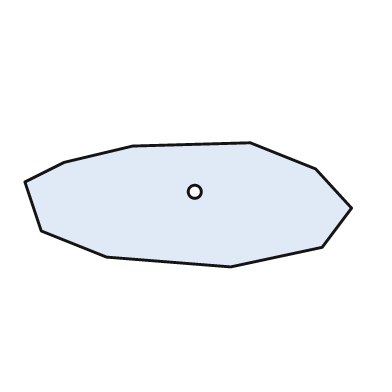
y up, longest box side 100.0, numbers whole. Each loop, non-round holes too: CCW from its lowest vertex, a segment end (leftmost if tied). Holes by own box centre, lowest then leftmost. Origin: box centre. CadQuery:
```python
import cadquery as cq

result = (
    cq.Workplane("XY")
    .moveTo(13.0, -19.0)
    .lineTo(41.0, -13.0)
    .lineTo(50.0, -1.0)
    .lineTo(39.0, 11.0)
    .lineTo(19.0, 19.0)
    .lineTo(-17.0, 18.0)
    .lineTo(-38.0, 13.0)
    .lineTo(-50.0, 7.0)
    .lineTo(-45.0, -8.0)
    .lineTo(-25.0, -16.0)
    .close()
    .moveTo(2.0, 4.0)
    .circle(2.0)
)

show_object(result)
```